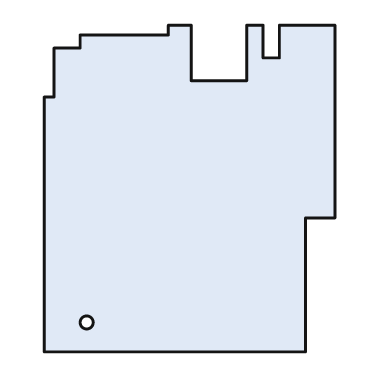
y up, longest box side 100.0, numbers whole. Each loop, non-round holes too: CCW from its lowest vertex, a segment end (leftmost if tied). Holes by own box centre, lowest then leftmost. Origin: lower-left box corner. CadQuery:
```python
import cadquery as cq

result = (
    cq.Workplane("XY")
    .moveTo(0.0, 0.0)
    .lineTo(80.0, 0.0)
    .lineTo(80.0, 41.0)
    .lineTo(89.0, 41.0)
    .lineTo(89.0, 100.0)
    .lineTo(72.0, 100.0)
    .lineTo(72.0, 90.0)
    .lineTo(67.0, 90.0)
    .lineTo(67.0, 100.0)
    .lineTo(62.0, 100.0)
    .lineTo(62.0, 83.0)
    .lineTo(45.0, 83.0)
    .lineTo(45.0, 100.0)
    .lineTo(38.0, 100.0)
    .lineTo(38.0, 97.0)
    .lineTo(11.0, 97.0)
    .lineTo(11.0, 93.0)
    .lineTo(3.0, 93.0)
    .lineTo(3.0, 78.0)
    .lineTo(0.0, 78.0)
    .close()
    .moveTo(13.0, 9.0)
    .circle(2.0)
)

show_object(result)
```